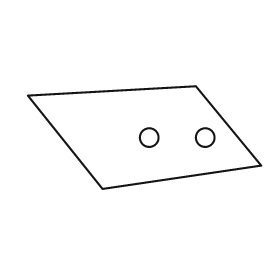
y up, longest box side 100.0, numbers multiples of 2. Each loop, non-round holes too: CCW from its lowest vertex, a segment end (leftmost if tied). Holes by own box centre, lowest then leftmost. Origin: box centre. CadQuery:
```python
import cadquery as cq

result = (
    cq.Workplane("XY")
    .moveTo(-18.0, -22.0)
    .lineTo(50.0, -12.0)
    .lineTo(22.0, 22.0)
    .lineTo(-50.0, 18.0)
    .close()
    .moveTo(2.0, 0.0)
    .circle(4.0)
    .moveTo(26.0, 0.0)
    .circle(4.0)
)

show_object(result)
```